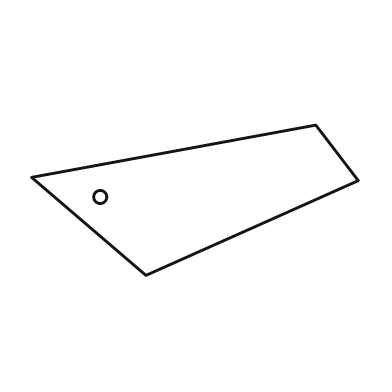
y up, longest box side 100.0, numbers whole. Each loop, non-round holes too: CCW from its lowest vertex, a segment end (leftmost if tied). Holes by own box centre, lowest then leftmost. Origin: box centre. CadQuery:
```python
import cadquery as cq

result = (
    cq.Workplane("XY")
    .moveTo(-15.0, -23.0)
    .lineTo(50.0, 6.0)
    .lineTo(37.0, 23.0)
    .lineTo(-50.0, 7.0)
    .close()
    .moveTo(-29.0, 1.0)
    .circle(2.0)
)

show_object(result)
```